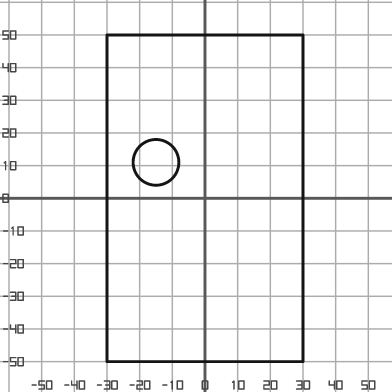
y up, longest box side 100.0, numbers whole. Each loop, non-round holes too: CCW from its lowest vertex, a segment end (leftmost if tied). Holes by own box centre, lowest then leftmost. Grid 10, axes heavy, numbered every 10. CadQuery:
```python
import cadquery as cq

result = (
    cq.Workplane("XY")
    .moveTo(-30.0, -50.0)
    .lineTo(30.0, -50.0)
    .lineTo(30.0, 50.0)
    .lineTo(-30.0, 50.0)
    .close()
    .moveTo(-15.0, 11.0)
    .circle(7.0)
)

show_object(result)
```